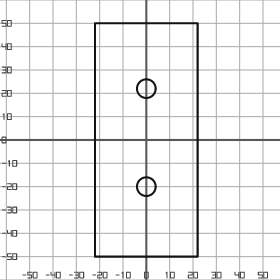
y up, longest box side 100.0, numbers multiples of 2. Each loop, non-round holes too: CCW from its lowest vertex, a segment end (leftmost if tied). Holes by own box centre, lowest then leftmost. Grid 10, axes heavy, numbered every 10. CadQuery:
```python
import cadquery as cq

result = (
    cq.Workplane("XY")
    .moveTo(-22.0, -50.0)
    .lineTo(22.0, -50.0)
    .lineTo(22.0, 50.0)
    .lineTo(-22.0, 50.0)
    .close()
    .moveTo(0.0, -20.0)
    .circle(4.0)
    .moveTo(0.0, 22.0)
    .circle(4.0)
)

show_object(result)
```